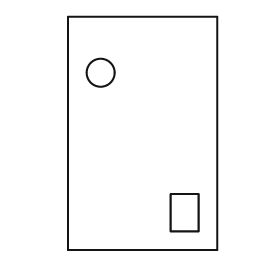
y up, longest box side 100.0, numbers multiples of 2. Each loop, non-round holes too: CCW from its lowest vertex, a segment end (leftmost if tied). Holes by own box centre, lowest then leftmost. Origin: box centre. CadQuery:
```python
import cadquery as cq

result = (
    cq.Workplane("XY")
    .moveTo(-32.0, -50.0)
    .lineTo(32.0, -50.0)
    .lineTo(32.0, 50.0)
    .lineTo(-32.0, 50.0)
    .close()
    .moveTo(12.0, -42.0)
    .lineTo(24.0, -42.0)
    .lineTo(24.0, -26.0)
    .lineTo(12.0, -26.0)
    .close()
    .moveTo(-18.0, 26.0)
    .circle(6.0)
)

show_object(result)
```